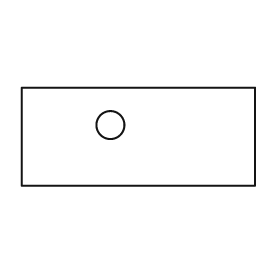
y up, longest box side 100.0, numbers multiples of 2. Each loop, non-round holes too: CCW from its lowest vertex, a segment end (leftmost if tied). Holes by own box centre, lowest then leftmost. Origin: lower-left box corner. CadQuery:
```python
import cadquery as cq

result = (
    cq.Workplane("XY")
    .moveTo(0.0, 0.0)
    .lineTo(100.0, 0.0)
    .lineTo(100.0, 42.0)
    .lineTo(0.0, 42.0)
    .close()
    .moveTo(38.0, 26.0)
    .circle(6.0)
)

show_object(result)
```